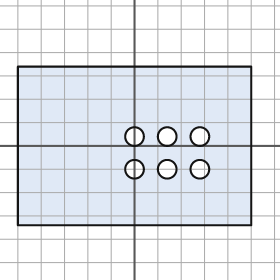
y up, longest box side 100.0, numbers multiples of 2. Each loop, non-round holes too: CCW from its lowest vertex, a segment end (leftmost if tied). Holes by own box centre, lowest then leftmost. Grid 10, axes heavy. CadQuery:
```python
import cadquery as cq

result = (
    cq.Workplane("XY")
    .moveTo(-50.0, -34.0)
    .lineTo(50.0, -34.0)
    .lineTo(50.0, 34.0)
    .lineTo(-50.0, 34.0)
    .close()
    .moveTo(0.0, -10.0)
    .circle(4.0)
    .moveTo(14.0, -10.0)
    .circle(4.0)
    .moveTo(28.0, -10.0)
    .circle(4.0)
    .moveTo(0.0, 4.0)
    .circle(4.0)
    .moveTo(14.0, 4.0)
    .circle(4.0)
    .moveTo(28.0, 4.0)
    .circle(4.0)
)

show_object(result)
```